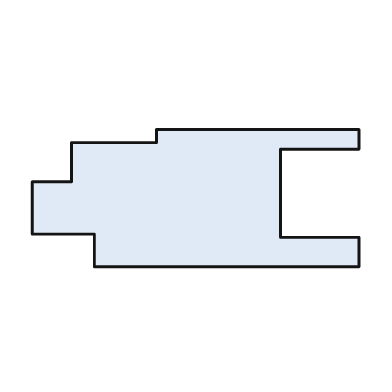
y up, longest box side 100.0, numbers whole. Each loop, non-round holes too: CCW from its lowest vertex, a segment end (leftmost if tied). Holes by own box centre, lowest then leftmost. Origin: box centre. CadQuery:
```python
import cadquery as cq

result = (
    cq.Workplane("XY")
    .moveTo(-31.0, -21.0)
    .lineTo(50.0, -21.0)
    .lineTo(50.0, -12.0)
    .lineTo(26.0, -12.0)
    .lineTo(26.0, 15.0)
    .lineTo(50.0, 15.0)
    .lineTo(50.0, 21.0)
    .lineTo(-12.0, 21.0)
    .lineTo(-12.0, 17.0)
    .lineTo(-38.0, 17.0)
    .lineTo(-38.0, 5.0)
    .lineTo(-50.0, 5.0)
    .lineTo(-50.0, -11.0)
    .lineTo(-31.0, -11.0)
    .close()
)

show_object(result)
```